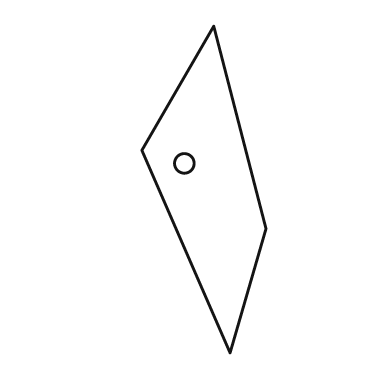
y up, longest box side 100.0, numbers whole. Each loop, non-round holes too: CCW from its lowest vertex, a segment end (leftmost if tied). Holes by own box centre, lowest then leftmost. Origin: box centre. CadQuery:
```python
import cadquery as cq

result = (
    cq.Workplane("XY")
    .moveTo(8.0, -50.0)
    .lineTo(19.0, -12.0)
    .lineTo(3.0, 50.0)
    .lineTo(-19.0, 12.0)
    .close()
    .moveTo(-6.0, 8.0)
    .circle(3.0)
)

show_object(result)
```